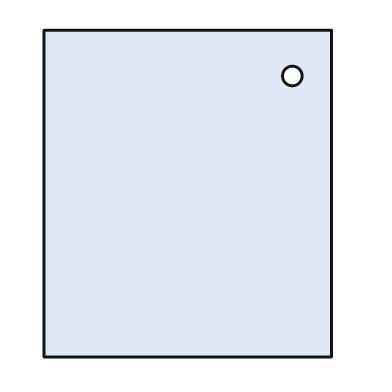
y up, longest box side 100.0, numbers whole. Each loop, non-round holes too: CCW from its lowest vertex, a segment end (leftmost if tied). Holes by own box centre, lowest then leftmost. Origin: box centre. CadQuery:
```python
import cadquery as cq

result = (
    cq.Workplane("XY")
    .moveTo(-44.0, -50.0)
    .lineTo(44.0, -50.0)
    .lineTo(44.0, 50.0)
    .lineTo(-44.0, 50.0)
    .close()
    .moveTo(32.0, 36.0)
    .circle(3.0)
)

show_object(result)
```